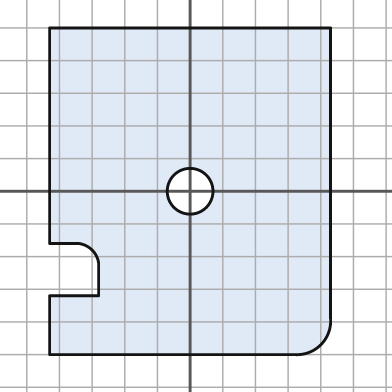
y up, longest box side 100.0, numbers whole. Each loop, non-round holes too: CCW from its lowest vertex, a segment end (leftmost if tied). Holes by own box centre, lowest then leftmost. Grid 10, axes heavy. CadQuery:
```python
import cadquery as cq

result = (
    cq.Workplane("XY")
    .moveTo(-43.0, -50.0)
    .lineTo(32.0, -50.0)
    .threePointArc((40.0, -47.0), (43.0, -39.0))
    .lineTo(43.0, 50.0)
    .lineTo(-43.0, 50.0)
    .lineTo(-43.0, -16.0)
    .lineTo(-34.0, -16.0)
    .threePointArc((-30.0, -18.0), (-28.0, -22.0))
    .lineTo(-28.0, -32.0)
    .lineTo(-43.0, -32.0)
    .close()
    .moveTo(0.0, 0.0)
    .circle(7.0)
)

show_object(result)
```